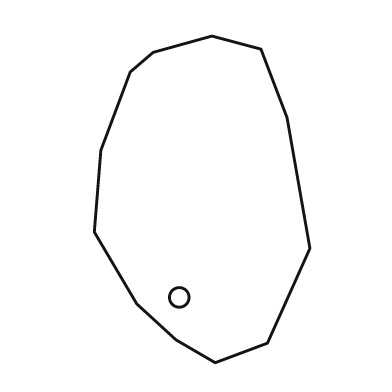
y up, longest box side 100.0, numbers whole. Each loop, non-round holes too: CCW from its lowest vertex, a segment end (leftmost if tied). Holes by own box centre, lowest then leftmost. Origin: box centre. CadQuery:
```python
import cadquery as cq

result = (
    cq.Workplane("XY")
    .moveTo(4.0, -50.0)
    .lineTo(20.0, -44.0)
    .lineTo(33.0, -15.0)
    .lineTo(26.0, 25.0)
    .lineTo(18.0, 46.0)
    .lineTo(3.0, 50.0)
    .lineTo(-15.0, 45.0)
    .lineTo(-22.0, 39.0)
    .lineTo(-31.0, 15.0)
    .lineTo(-33.0, -10.0)
    .lineTo(-20.0, -32.0)
    .lineTo(-8.0, -43.0)
    .close()
    .moveTo(-7.0, -30.0)
    .circle(3.0)
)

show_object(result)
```